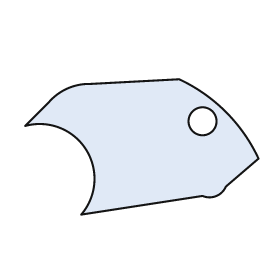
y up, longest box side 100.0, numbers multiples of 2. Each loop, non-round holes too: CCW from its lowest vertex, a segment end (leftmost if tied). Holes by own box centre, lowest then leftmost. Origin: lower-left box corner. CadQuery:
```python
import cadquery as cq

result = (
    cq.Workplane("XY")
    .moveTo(24.0, 0.0)
    .lineTo(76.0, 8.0)
    .threePointArc((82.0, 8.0), (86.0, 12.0))
    .lineTo(100.0, 24.0)
    .threePointArc((86.0, 44.0), (66.0, 58.0))
    .lineTo(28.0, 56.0)
    .threePointArc((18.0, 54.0), (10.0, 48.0))
    .lineTo(0.0, 38.0)
    .threePointArc((26.0, 28.0), (24.0, 0.0))
    .close()
    .moveTo(76.0, 40.0)
    .circle(6.0)
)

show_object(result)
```